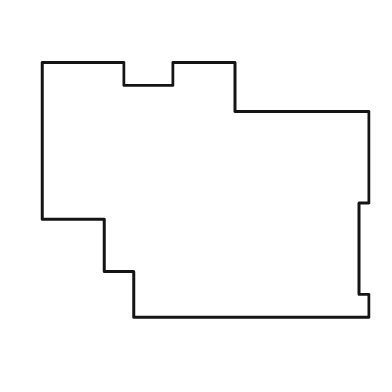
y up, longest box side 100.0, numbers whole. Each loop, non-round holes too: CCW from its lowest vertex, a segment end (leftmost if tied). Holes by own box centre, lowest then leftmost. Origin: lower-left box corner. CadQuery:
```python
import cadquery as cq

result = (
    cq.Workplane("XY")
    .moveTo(28.0, 0.0)
    .lineTo(100.0, 0.0)
    .lineTo(100.0, 7.0)
    .lineTo(97.0, 7.0)
    .lineTo(97.0, 35.0)
    .lineTo(100.0, 35.0)
    .lineTo(100.0, 63.0)
    .lineTo(59.0, 63.0)
    .lineTo(59.0, 78.0)
    .lineTo(40.0, 78.0)
    .lineTo(40.0, 71.0)
    .lineTo(25.0, 71.0)
    .lineTo(25.0, 78.0)
    .lineTo(0.0, 78.0)
    .lineTo(0.0, 30.0)
    .lineTo(19.0, 30.0)
    .lineTo(19.0, 14.0)
    .lineTo(28.0, 14.0)
    .close()
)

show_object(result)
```